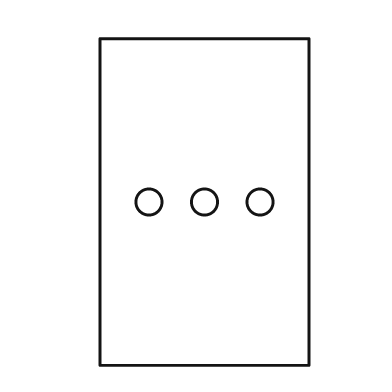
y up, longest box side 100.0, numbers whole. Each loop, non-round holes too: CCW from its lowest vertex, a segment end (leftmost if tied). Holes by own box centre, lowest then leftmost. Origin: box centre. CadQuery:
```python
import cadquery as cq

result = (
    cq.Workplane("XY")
    .moveTo(-32.0, -50.0)
    .lineTo(32.0, -50.0)
    .lineTo(32.0, 50.0)
    .lineTo(-32.0, 50.0)
    .close()
    .moveTo(-17.0, 0.0)
    .circle(4.0)
    .moveTo(0.0, 0.0)
    .circle(4.0)
    .moveTo(17.0, 0.0)
    .circle(4.0)
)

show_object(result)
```